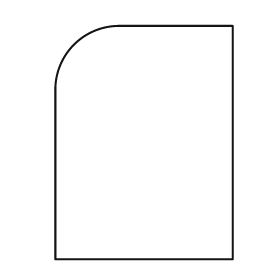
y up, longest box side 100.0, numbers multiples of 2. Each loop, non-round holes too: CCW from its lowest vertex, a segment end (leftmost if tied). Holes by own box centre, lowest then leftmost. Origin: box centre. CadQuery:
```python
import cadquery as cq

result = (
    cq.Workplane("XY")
    .moveTo(-38.0, -50.0)
    .lineTo(38.0, -50.0)
    .lineTo(38.0, 50.0)
    .lineTo(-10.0, 50.0)
    .threePointArc((-30.0, 42.0), (-38.0, 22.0))
    .close()
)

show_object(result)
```